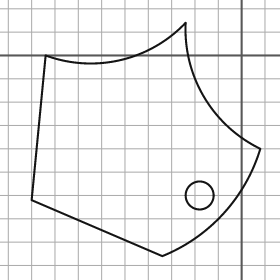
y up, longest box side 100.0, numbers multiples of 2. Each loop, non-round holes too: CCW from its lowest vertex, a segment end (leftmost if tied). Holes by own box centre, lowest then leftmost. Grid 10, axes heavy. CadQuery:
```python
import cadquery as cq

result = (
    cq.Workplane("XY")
    .moveTo(-34.0, -86.0)
    .threePointArc((-8.0, -68.0), (8.0, -40.0))
    .threePointArc((-16.0, -18.0), (-24.0, 14.0))
    .threePointArc((-52.0, -2.0), (-84.0, 0.0))
    .lineTo(-90.0, -62.0)
    .close()
    .moveTo(-18.0, -60.0)
    .circle(6.0)
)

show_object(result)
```